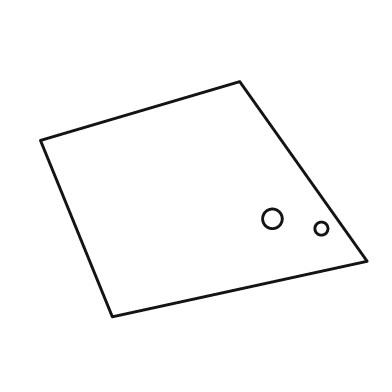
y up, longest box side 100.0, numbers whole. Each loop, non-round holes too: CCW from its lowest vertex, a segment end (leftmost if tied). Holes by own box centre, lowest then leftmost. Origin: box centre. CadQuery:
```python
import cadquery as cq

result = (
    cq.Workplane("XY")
    .moveTo(-28.0, -36.0)
    .lineTo(50.0, -19.0)
    .lineTo(11.0, 36.0)
    .lineTo(-50.0, 18.0)
    .close()
    .moveTo(36.0, -9.0)
    .circle(2.0)
    .moveTo(21.0, -6.0)
    .circle(3.0)
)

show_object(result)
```